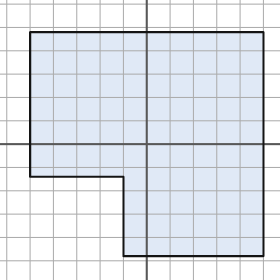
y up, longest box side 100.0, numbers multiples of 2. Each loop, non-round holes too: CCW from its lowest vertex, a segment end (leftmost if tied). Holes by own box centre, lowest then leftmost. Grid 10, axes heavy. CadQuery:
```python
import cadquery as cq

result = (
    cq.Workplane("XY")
    .moveTo(-10.0, -48.0)
    .lineTo(50.0, -48.0)
    .lineTo(50.0, 48.0)
    .lineTo(-50.0, 48.0)
    .lineTo(-50.0, -14.0)
    .lineTo(-10.0, -14.0)
    .close()
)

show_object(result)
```